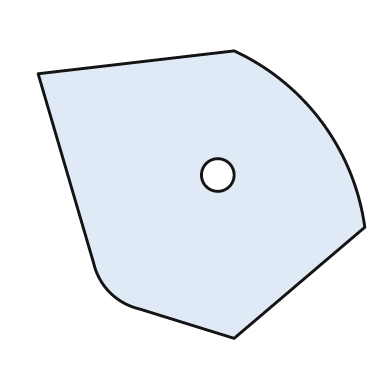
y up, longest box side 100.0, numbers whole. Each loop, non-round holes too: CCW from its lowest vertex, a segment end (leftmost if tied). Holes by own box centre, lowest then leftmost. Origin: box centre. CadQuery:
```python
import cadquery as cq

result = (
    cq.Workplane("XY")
    .moveTo(10.0, -44.0)
    .lineTo(50.0, -10.0)
    .threePointArc((37.0, 22.0), (10.0, 44.0))
    .lineTo(-50.0, 37.0)
    .lineTo(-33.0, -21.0)
    .threePointArc((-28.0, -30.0), (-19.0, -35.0))
    .close()
    .moveTo(5.0, 6.0)
    .circle(5.0)
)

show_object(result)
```